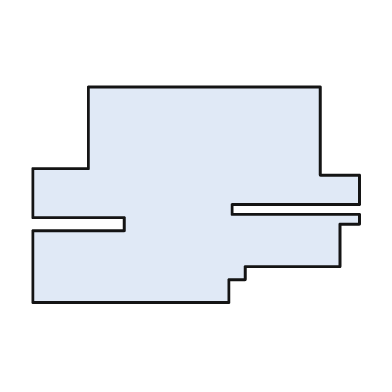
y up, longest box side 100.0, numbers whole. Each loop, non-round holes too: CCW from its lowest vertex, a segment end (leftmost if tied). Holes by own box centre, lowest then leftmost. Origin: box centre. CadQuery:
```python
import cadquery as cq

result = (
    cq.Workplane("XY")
    .moveTo(-50.0, -33.0)
    .lineTo(10.0, -33.0)
    .lineTo(10.0, -26.0)
    .lineTo(15.0, -26.0)
    .lineTo(15.0, -22.0)
    .lineTo(44.0, -22.0)
    .lineTo(44.0, -9.0)
    .lineTo(50.0, -9.0)
    .lineTo(50.0, -6.0)
    .lineTo(11.0, -6.0)
    .lineTo(11.0, -3.0)
    .lineTo(50.0, -3.0)
    .lineTo(50.0, 6.0)
    .lineTo(38.0, 6.0)
    .lineTo(38.0, 33.0)
    .lineTo(-33.0, 33.0)
    .lineTo(-33.0, 8.0)
    .lineTo(-50.0, 8.0)
    .lineTo(-50.0, -7.0)
    .lineTo(-22.0, -7.0)
    .lineTo(-22.0, -11.0)
    .lineTo(-50.0, -11.0)
    .close()
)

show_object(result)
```